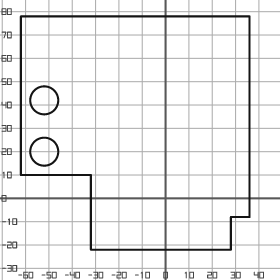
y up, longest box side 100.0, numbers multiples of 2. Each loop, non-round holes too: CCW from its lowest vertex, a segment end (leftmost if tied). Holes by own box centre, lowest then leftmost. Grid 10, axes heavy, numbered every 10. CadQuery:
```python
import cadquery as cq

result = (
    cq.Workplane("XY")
    .moveTo(-32.0, -22.0)
    .lineTo(28.0, -22.0)
    .lineTo(28.0, -8.0)
    .lineTo(36.0, -8.0)
    .lineTo(36.0, 78.0)
    .lineTo(-62.0, 78.0)
    .lineTo(-62.0, 10.0)
    .lineTo(-32.0, 10.0)
    .close()
    .moveTo(-52.0, 20.0)
    .circle(6.0)
    .moveTo(-52.0, 42.0)
    .circle(6.0)
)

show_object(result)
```